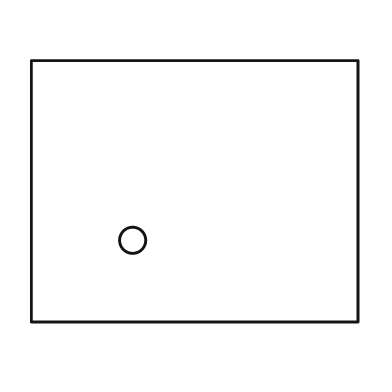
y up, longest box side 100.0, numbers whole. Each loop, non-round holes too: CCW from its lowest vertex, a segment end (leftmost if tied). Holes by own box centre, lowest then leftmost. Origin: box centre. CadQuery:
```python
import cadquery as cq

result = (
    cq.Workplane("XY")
    .moveTo(-50.0, -40.0)
    .lineTo(50.0, -40.0)
    .lineTo(50.0, 40.0)
    .lineTo(-50.0, 40.0)
    .close()
    .moveTo(-19.0, -15.0)
    .circle(4.0)
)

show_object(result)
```